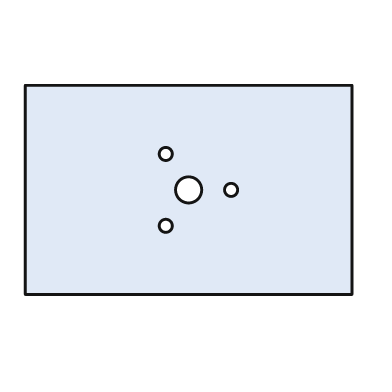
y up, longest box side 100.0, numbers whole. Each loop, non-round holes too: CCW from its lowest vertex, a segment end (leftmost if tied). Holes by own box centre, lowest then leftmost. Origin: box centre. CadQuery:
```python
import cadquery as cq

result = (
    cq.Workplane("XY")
    .moveTo(-50.0, -32.0)
    .lineTo(50.0, -32.0)
    .lineTo(50.0, 32.0)
    .lineTo(-50.0, 32.0)
    .close()
    .moveTo(-7.0, -11.0)
    .circle(2.0)
    .moveTo(0.0, 0.0)
    .circle(4.0)
    .moveTo(13.0, 0.0)
    .circle(2.0)
    .moveTo(-7.0, 11.0)
    .circle(2.0)
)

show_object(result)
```